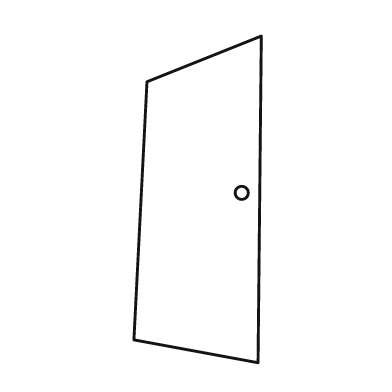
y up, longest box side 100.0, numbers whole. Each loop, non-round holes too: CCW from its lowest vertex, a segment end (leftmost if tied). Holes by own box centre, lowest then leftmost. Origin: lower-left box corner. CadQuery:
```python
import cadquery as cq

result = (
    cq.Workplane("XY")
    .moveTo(38.0, 0.0)
    .lineTo(39.0, 100.0)
    .lineTo(4.0, 86.0)
    .lineTo(0.0, 7.0)
    .close()
    .moveTo(33.0, 52.0)
    .circle(2.0)
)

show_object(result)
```